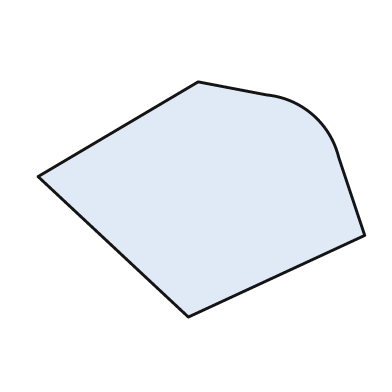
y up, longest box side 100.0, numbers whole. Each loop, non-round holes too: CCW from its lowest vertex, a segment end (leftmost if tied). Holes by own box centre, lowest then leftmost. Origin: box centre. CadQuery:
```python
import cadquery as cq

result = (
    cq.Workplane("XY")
    .moveTo(-4.0, -36.0)
    .lineTo(50.0, -11.0)
    .lineTo(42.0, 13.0)
    .threePointArc((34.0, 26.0), (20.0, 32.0))
    .lineTo(-1.0, 36.0)
    .lineTo(-50.0, 7.0)
    .close()
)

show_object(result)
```